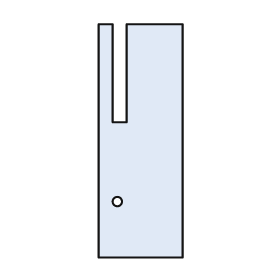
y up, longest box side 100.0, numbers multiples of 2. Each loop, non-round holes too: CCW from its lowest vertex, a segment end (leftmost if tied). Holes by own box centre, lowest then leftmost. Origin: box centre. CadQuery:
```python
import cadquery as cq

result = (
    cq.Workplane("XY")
    .moveTo(-18.0, -50.0)
    .lineTo(18.0, -50.0)
    .lineTo(18.0, 50.0)
    .lineTo(-6.0, 50.0)
    .lineTo(-6.0, 8.0)
    .lineTo(-12.0, 8.0)
    .lineTo(-12.0, 50.0)
    .lineTo(-18.0, 50.0)
    .close()
    .moveTo(-10.0, -26.0)
    .circle(2.0)
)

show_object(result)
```